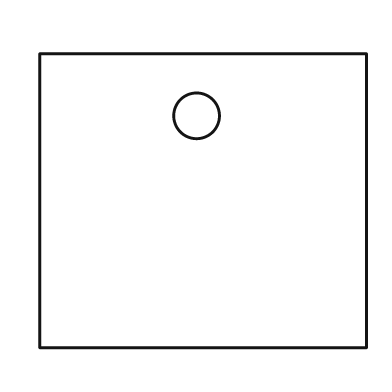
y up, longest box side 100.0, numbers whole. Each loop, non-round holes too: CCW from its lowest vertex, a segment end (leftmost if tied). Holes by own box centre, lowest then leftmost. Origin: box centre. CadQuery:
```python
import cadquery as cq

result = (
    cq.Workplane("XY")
    .moveTo(-50.0, -45.0)
    .lineTo(50.0, -45.0)
    .lineTo(50.0, 45.0)
    .lineTo(-50.0, 45.0)
    .close()
    .moveTo(-2.0, 26.0)
    .circle(7.0)
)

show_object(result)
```